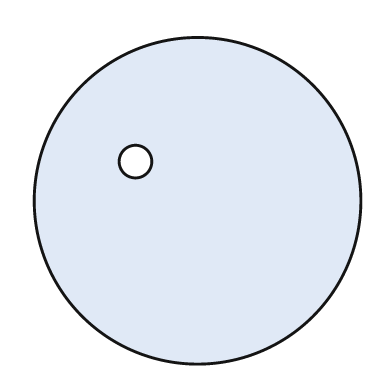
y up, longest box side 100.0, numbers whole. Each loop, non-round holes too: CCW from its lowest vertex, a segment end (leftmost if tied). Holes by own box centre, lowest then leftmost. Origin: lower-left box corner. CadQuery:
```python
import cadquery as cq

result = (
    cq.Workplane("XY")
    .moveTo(50.0, 50.0)
    .circle(50.0)
    .moveTo(31.0, 62.0)
    .circle(5.0)
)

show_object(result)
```